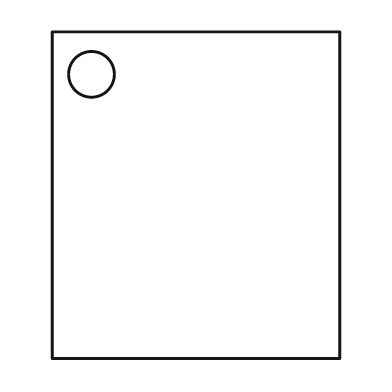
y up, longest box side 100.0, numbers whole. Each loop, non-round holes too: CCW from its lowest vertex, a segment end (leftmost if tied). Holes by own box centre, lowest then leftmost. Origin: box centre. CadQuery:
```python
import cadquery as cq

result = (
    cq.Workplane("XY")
    .moveTo(-44.0, -50.0)
    .lineTo(44.0, -50.0)
    .lineTo(44.0, 50.0)
    .lineTo(-44.0, 50.0)
    .close()
    .moveTo(-32.0, 37.0)
    .circle(7.0)
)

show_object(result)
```